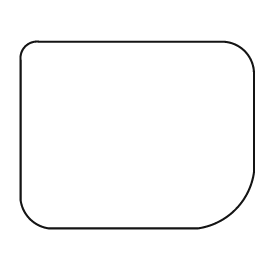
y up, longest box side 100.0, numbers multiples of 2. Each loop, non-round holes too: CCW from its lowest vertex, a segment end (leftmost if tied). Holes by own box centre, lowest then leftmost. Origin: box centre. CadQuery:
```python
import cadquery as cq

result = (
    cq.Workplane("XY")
    .moveTo(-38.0, -40.0)
    .lineTo(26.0, -40.0)
    .threePointArc((42.0, -32.0), (50.0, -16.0))
    .lineTo(50.0, 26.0)
    .threePointArc((46.0, 36.0), (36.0, 40.0))
    .lineTo(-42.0, 40.0)
    .threePointArc((-48.0, 38.0), (-50.0, 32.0))
    .lineTo(-50.0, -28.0)
    .threePointArc((-46.0, -36.0), (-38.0, -40.0))
    .close()
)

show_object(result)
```